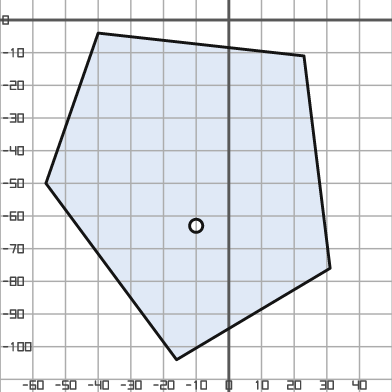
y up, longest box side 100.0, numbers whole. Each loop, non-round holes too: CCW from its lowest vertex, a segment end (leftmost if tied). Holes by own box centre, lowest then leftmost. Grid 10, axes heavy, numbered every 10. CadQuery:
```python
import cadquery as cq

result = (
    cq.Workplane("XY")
    .moveTo(-16.0, -104.0)
    .lineTo(31.0, -76.0)
    .lineTo(23.0, -11.0)
    .lineTo(-40.0, -4.0)
    .lineTo(-56.0, -50.0)
    .close()
    .moveTo(-10.0, -63.0)
    .circle(2.0)
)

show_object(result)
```